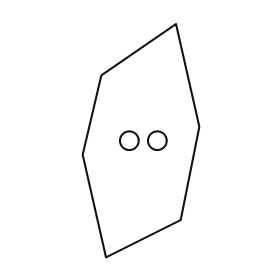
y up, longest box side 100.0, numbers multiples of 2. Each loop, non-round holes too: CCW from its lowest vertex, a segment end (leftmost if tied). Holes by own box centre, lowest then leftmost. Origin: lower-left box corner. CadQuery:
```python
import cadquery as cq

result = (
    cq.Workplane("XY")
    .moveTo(10.0, 0.0)
    .lineTo(42.0, 16.0)
    .lineTo(50.0, 56.0)
    .lineTo(40.0, 100.0)
    .lineTo(8.0, 78.0)
    .lineTo(0.0, 44.0)
    .close()
    .moveTo(20.0, 50.0)
    .circle(4.0)
    .moveTo(32.0, 50.0)
    .circle(4.0)
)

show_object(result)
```